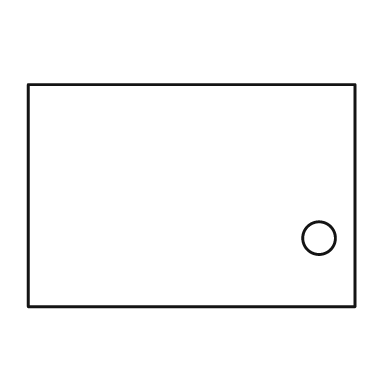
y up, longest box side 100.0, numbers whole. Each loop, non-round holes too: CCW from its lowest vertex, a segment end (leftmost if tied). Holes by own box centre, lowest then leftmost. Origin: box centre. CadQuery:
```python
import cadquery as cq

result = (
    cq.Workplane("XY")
    .moveTo(-50.0, -34.0)
    .lineTo(50.0, -34.0)
    .lineTo(50.0, 34.0)
    .lineTo(-50.0, 34.0)
    .close()
    .moveTo(39.0, -13.0)
    .circle(5.0)
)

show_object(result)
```